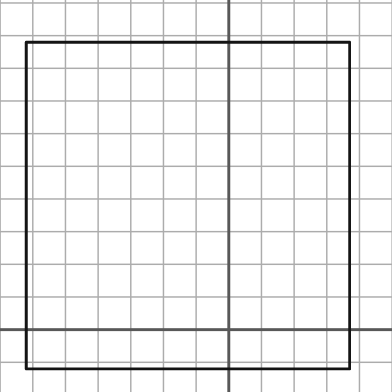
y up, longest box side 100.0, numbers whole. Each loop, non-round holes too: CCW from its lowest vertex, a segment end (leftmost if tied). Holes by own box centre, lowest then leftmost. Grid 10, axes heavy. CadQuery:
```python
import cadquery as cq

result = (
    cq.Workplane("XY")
    .moveTo(-62.0, -12.0)
    .lineTo(37.0, -12.0)
    .lineTo(37.0, 88.0)
    .lineTo(-62.0, 88.0)
    .close()
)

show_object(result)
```